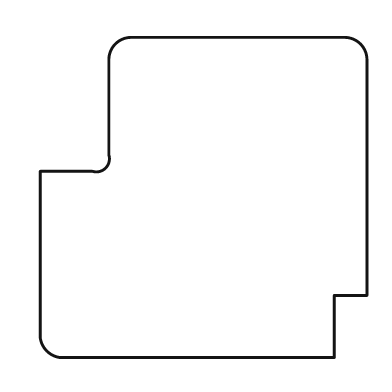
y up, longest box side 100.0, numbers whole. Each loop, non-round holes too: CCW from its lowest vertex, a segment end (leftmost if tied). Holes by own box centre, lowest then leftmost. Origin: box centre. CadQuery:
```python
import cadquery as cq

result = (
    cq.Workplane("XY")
    .moveTo(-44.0, -49.0)
    .lineTo(40.0, -49.0)
    .lineTo(40.0, -30.0)
    .lineTo(50.0, -30.0)
    .lineTo(50.0, 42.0)
    .threePointArc((48.0, 47.0), (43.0, 49.0))
    .lineTo(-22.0, 49.0)
    .threePointArc((-27.0, 47.0), (-29.0, 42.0))
    .lineTo(-29.0, 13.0)
    .threePointArc((-30.0, 9.0), (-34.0, 8.0))
    .lineTo(-50.0, 8.0)
    .lineTo(-50.0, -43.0)
    .threePointArc((-48.0, -47.0), (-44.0, -49.0))
    .close()
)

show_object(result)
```